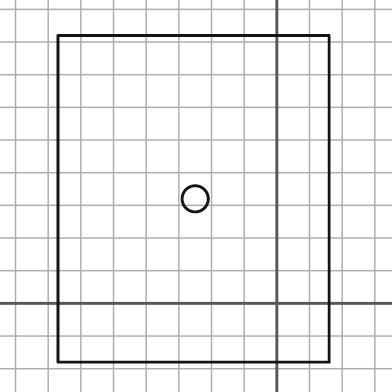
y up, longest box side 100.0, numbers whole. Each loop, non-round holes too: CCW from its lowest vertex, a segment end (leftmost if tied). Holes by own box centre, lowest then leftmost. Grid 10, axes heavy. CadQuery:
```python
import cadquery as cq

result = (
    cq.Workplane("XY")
    .moveTo(-67.0, -18.0)
    .lineTo(16.0, -18.0)
    .lineTo(16.0, 82.0)
    .lineTo(-67.0, 82.0)
    .close()
    .moveTo(-25.0, 32.0)
    .circle(4.0)
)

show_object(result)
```